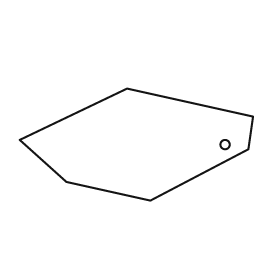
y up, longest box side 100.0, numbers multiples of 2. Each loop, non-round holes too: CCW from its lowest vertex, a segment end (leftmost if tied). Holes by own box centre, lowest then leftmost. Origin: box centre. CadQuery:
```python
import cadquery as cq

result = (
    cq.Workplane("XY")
    .moveTo(6.0, -24.0)
    .lineTo(48.0, -2.0)
    .lineTo(50.0, 12.0)
    .lineTo(-4.0, 24.0)
    .lineTo(-50.0, 2.0)
    .lineTo(-30.0, -16.0)
    .close()
    .moveTo(38.0, 0.0)
    .circle(2.0)
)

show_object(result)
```